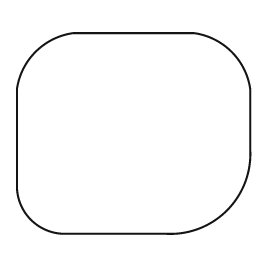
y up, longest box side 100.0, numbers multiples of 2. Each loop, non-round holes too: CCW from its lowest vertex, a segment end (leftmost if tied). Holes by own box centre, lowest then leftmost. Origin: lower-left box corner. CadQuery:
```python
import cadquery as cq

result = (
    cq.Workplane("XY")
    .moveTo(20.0, 0.0)
    .lineTo(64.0, 0.0)
    .threePointArc((90.0, 10.0), (100.0, 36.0))
    .lineTo(100.0, 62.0)
    .threePointArc((92.0, 78.0), (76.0, 86.0))
    .lineTo(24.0, 86.0)
    .threePointArc((8.0, 78.0), (0.0, 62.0))
    .lineTo(0.0, 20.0)
    .threePointArc((6.0, 6.0), (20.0, 0.0))
    .close()
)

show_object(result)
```